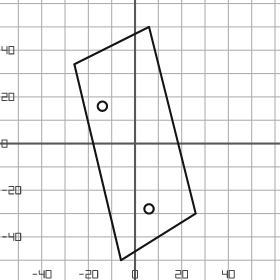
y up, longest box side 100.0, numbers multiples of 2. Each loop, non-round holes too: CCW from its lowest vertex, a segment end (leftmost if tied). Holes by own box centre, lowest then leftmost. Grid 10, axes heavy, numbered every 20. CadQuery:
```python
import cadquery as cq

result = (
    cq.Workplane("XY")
    .moveTo(-6.0, -50.0)
    .lineTo(26.0, -30.0)
    .lineTo(6.0, 50.0)
    .lineTo(-26.0, 34.0)
    .close()
    .moveTo(6.0, -28.0)
    .circle(2.0)
    .moveTo(-14.0, 16.0)
    .circle(2.0)
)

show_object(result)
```